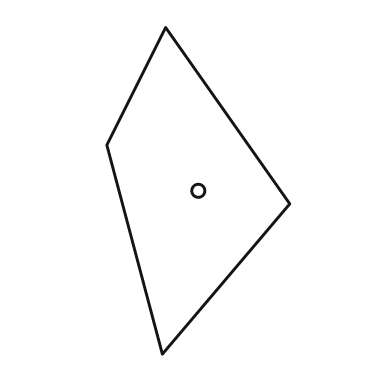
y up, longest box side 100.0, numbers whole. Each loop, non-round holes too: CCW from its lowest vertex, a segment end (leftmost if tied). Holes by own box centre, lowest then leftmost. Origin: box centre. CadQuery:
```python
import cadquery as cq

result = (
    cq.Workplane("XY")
    .moveTo(-11.0, -50.0)
    .lineTo(28.0, -4.0)
    .lineTo(-10.0, 50.0)
    .lineTo(-28.0, 14.0)
    .close()
    .moveTo(0.0, 0.0)
    .circle(2.0)
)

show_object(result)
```